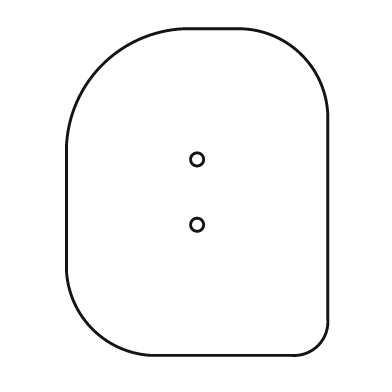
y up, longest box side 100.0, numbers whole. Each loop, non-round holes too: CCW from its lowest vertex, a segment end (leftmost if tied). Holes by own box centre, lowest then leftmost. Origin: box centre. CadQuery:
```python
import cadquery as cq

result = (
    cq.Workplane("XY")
    .moveTo(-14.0, -50.0)
    .lineTo(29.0, -50.0)
    .threePointArc((37.0, -47.0), (40.0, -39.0))
    .lineTo(40.0, 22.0)
    .threePointArc((32.0, 42.0), (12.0, 50.0))
    .lineTo(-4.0, 50.0)
    .threePointArc((-29.0, 39.0), (-40.0, 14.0))
    .lineTo(-40.0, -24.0)
    .threePointArc((-32.0, -42.0), (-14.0, -50.0))
    .close()
    .moveTo(0.0, -10.0)
    .circle(2.0)
    .moveTo(0.0, 10.0)
    .circle(2.0)
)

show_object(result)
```